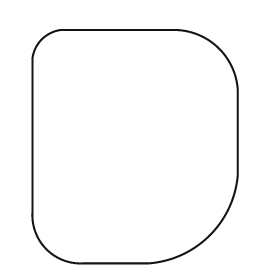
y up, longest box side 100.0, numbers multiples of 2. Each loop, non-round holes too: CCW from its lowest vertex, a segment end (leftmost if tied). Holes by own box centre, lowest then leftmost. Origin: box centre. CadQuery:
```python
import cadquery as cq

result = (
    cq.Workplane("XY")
    .moveTo(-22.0, -50.0)
    .lineTo(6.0, -50.0)
    .threePointArc((32.0, -38.0), (44.0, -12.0))
    .lineTo(44.0, 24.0)
    .threePointArc((36.0, 42.0), (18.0, 50.0))
    .lineTo(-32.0, 50.0)
    .threePointArc((-40.0, 46.0), (-44.0, 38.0))
    .lineTo(-44.0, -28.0)
    .threePointArc((-38.0, -44.0), (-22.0, -50.0))
    .close()
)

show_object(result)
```